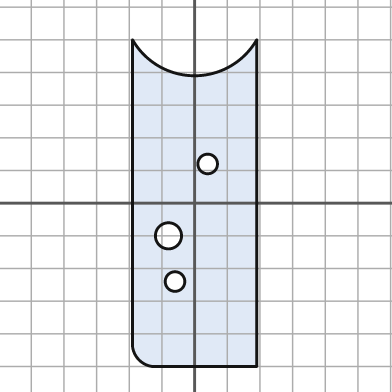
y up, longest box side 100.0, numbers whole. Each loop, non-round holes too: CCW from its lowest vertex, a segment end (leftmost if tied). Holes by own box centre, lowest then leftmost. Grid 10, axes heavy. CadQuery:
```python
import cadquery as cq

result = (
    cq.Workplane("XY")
    .moveTo(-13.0, -50.0)
    .lineTo(19.0, -50.0)
    .lineTo(19.0, 50.0)
    .threePointArc((0.0, 39.0), (-19.0, 50.0))
    .lineTo(-19.0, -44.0)
    .threePointArc((-17.0, -48.0), (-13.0, -50.0))
    .close()
    .moveTo(-6.0, -24.0)
    .circle(3.0)
    .moveTo(-8.0, -10.0)
    .circle(4.0)
    .moveTo(4.0, 12.0)
    .circle(3.0)
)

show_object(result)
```